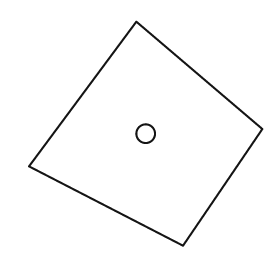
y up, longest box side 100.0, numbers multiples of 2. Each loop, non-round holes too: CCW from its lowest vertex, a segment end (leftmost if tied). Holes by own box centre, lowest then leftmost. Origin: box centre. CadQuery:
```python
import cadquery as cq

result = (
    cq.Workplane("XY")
    .moveTo(16.0, -48.0)
    .lineTo(50.0, 2.0)
    .lineTo(-4.0, 48.0)
    .lineTo(-50.0, -14.0)
    .close()
    .moveTo(0.0, 0.0)
    .circle(4.0)
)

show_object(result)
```